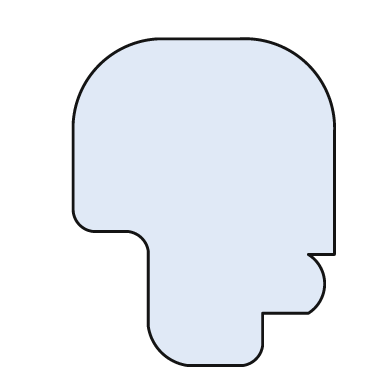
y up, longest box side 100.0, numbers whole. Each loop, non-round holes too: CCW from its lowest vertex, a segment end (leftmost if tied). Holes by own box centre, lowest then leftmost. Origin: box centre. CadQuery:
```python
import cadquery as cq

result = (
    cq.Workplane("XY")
    .moveTo(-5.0, -50.0)
    .lineTo(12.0, -50.0)
    .threePointArc((16.0, -48.0), (18.0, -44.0))
    .lineTo(18.0, -34.0)
    .lineTo(32.0, -34.0)
    .threePointArc((37.0, -25.0), (32.0, -16.0))
    .lineTo(40.0, -16.0)
    .lineTo(40.0, 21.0)
    .threePointArc((32.0, 42.0), (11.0, 50.0))
    .lineTo(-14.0, 50.0)
    .threePointArc((-32.0, 42.0), (-40.0, 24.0))
    .lineTo(-40.0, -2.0)
    .threePointArc((-38.0, -7.0), (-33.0, -9.0))
    .lineTo(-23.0, -9.0)
    .threePointArc((-19.0, -11.0), (-17.0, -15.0))
    .lineTo(-17.0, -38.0)
    .threePointArc((-13.0, -46.0), (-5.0, -50.0))
    .close()
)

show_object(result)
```